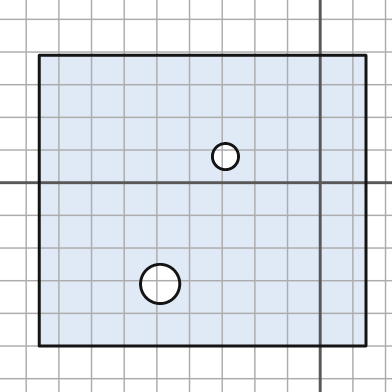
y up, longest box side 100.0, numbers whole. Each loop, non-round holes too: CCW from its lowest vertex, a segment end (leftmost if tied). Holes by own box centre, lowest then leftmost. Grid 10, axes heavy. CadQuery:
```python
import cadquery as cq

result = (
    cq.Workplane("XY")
    .moveTo(-86.0, -50.0)
    .lineTo(14.0, -50.0)
    .lineTo(14.0, 39.0)
    .lineTo(-86.0, 39.0)
    .close()
    .moveTo(-49.0, -31.0)
    .circle(6.0)
    .moveTo(-29.0, 8.0)
    .circle(4.0)
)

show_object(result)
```